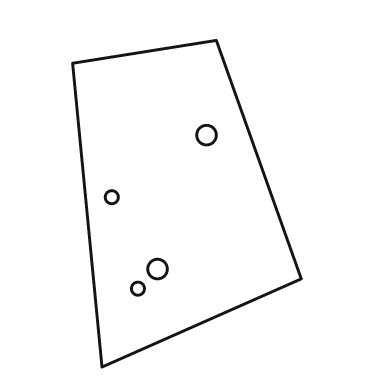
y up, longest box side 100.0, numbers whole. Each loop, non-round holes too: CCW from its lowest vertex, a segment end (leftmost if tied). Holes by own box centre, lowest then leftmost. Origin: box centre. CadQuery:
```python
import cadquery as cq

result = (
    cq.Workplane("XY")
    .moveTo(-26.0, -50.0)
    .lineTo(35.0, -23.0)
    .lineTo(9.0, 50.0)
    .lineTo(-35.0, 43.0)
    .close()
    .moveTo(-15.0, -26.0)
    .circle(2.0)
    .moveTo(-9.0, -20.0)
    .circle(3.0)
    .moveTo(-23.0, 2.0)
    .circle(2.0)
    .moveTo(6.0, 21.0)
    .circle(3.0)
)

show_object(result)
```